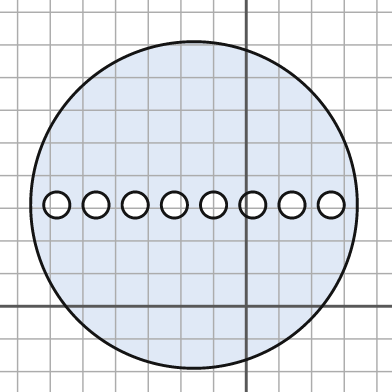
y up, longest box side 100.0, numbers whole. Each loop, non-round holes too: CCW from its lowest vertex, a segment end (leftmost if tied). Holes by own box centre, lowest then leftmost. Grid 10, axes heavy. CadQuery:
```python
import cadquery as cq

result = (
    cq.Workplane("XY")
    .moveTo(-16.0, 31.0)
    .circle(50.0)
    .moveTo(-58.0, 31.0)
    .circle(4.0)
    .moveTo(-46.0, 31.0)
    .circle(4.0)
    .moveTo(-34.0, 31.0)
    .circle(4.0)
    .moveTo(-22.0, 31.0)
    .circle(4.0)
    .moveTo(-10.0, 31.0)
    .circle(4.0)
    .moveTo(2.0, 31.0)
    .circle(4.0)
    .moveTo(14.0, 31.0)
    .circle(4.0)
    .moveTo(26.0, 31.0)
    .circle(4.0)
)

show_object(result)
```